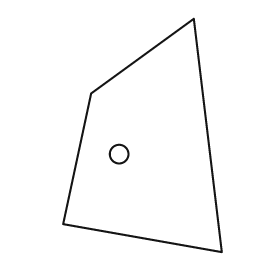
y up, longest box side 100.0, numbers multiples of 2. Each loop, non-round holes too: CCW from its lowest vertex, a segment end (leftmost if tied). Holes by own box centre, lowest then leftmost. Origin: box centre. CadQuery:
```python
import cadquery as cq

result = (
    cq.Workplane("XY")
    .moveTo(34.0, -50.0)
    .lineTo(22.0, 50.0)
    .lineTo(-22.0, 18.0)
    .lineTo(-34.0, -38.0)
    .close()
    .moveTo(-10.0, -8.0)
    .circle(4.0)
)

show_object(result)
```